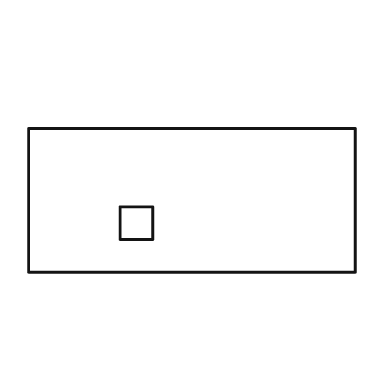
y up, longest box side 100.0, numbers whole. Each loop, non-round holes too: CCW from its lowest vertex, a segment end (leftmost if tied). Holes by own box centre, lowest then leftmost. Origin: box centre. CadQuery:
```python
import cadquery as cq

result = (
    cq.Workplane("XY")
    .moveTo(-50.0, -22.0)
    .lineTo(50.0, -22.0)
    .lineTo(50.0, 22.0)
    .lineTo(-50.0, 22.0)
    .close()
    .moveTo(-22.0, -12.0)
    .lineTo(-12.0, -12.0)
    .lineTo(-12.0, -2.0)
    .lineTo(-22.0, -2.0)
    .close()
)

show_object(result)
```